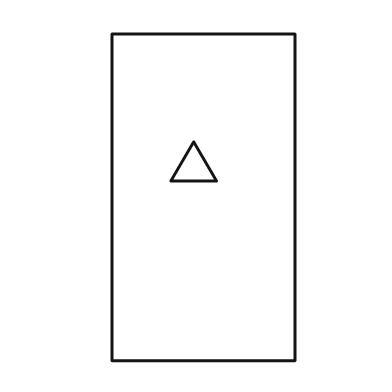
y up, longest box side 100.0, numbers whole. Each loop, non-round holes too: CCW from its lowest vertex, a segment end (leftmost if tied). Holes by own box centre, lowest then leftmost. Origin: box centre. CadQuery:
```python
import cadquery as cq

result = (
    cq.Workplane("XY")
    .moveTo(-28.0, -50.0)
    .lineTo(28.0, -50.0)
    .lineTo(28.0, 50.0)
    .lineTo(-28.0, 50.0)
    .close()
    .moveTo(-10.0, 5.0)
    .lineTo(4.0, 5.0)
    .lineTo(-3.0, 17.0)
    .close()
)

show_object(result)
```